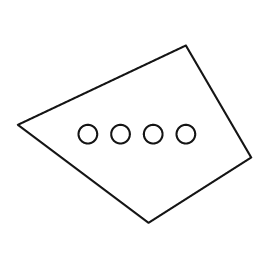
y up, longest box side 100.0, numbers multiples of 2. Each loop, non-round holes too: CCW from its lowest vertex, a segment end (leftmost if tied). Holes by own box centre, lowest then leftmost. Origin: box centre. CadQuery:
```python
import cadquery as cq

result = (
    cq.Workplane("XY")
    .moveTo(6.0, -38.0)
    .lineTo(50.0, -10.0)
    .lineTo(22.0, 38.0)
    .lineTo(-50.0, 4.0)
    .close()
    .moveTo(-20.0, 0.0)
    .circle(4.0)
    .moveTo(-6.0, 0.0)
    .circle(4.0)
    .moveTo(8.0, 0.0)
    .circle(4.0)
    .moveTo(22.0, 0.0)
    .circle(4.0)
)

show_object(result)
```